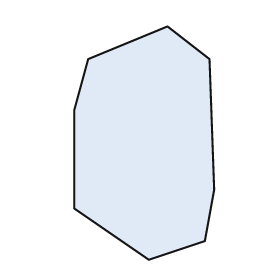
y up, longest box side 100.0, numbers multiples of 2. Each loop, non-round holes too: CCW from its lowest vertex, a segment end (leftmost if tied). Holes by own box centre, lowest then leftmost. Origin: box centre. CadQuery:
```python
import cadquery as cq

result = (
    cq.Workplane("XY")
    .moveTo(2.0, -50.0)
    .lineTo(26.0, -42.0)
    .lineTo(30.0, -20.0)
    .lineTo(28.0, 36.0)
    .lineTo(10.0, 50.0)
    .lineTo(-24.0, 36.0)
    .lineTo(-30.0, 14.0)
    .lineTo(-30.0, -28.0)
    .close()
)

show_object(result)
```